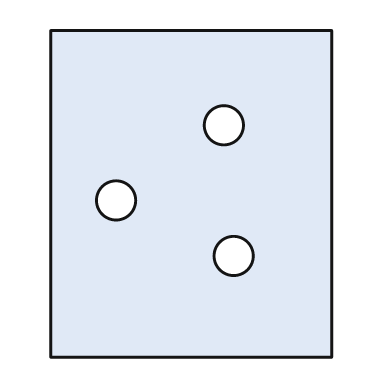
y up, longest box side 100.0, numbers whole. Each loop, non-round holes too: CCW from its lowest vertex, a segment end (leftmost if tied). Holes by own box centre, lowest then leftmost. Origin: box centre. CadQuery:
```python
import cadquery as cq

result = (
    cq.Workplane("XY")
    .moveTo(-43.0, -50.0)
    .lineTo(43.0, -50.0)
    .lineTo(43.0, 50.0)
    .lineTo(-43.0, 50.0)
    .close()
    .moveTo(13.0, -19.0)
    .circle(6.0)
    .moveTo(-23.0, -2.0)
    .circle(6.0)
    .moveTo(10.0, 21.0)
    .circle(6.0)
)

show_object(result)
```